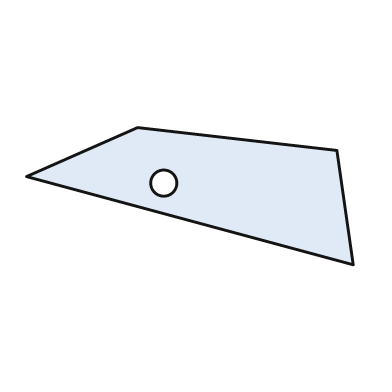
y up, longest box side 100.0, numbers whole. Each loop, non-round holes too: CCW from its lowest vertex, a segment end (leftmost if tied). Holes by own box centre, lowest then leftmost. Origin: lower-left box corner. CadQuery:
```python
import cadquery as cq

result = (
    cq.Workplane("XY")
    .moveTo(100.0, 0.0)
    .lineTo(95.0, 35.0)
    .lineTo(34.0, 42.0)
    .lineTo(0.0, 27.0)
    .close()
    .moveTo(42.0, 25.0)
    .circle(4.0)
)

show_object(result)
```